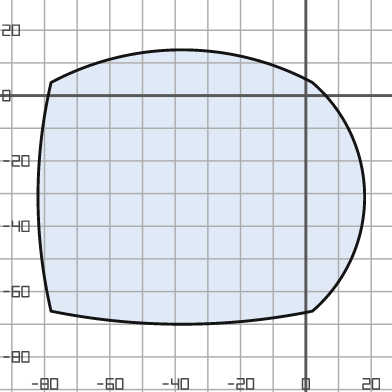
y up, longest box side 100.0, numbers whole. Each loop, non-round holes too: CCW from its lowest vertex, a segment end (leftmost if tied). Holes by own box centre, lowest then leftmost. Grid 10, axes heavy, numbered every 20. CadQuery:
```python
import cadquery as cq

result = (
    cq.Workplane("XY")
    .moveTo(-78.0, -66.0)
    .threePointArc((-38.0, -70.0), (2.0, -66.0))
    .threePointArc((18.0, -31.0), (2.0, 4.0))
    .threePointArc((-38.0, 14.0), (-78.0, 4.0))
    .threePointArc((-82.0, -31.0), (-78.0, -66.0))
    .close()
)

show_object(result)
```